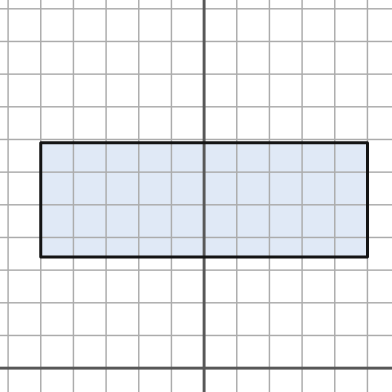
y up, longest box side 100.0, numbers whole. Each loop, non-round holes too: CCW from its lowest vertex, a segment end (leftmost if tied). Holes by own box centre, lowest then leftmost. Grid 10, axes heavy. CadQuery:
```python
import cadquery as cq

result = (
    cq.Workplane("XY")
    .moveTo(-50.0, 34.0)
    .lineTo(50.0, 34.0)
    .lineTo(50.0, 69.0)
    .lineTo(-50.0, 69.0)
    .close()
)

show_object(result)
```